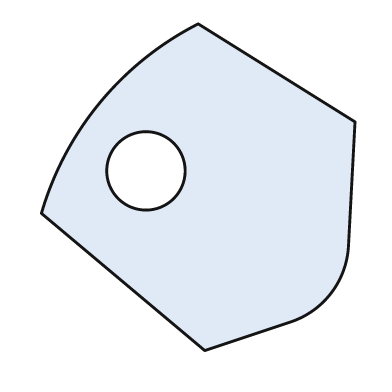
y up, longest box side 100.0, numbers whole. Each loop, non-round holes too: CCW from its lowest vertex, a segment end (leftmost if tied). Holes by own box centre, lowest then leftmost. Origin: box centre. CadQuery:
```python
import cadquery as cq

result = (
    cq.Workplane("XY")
    .moveTo(2.0, -50.0)
    .lineTo(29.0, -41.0)
    .threePointArc((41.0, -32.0), (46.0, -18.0))
    .lineTo(48.0, 20.0)
    .lineTo(0.0, 50.0)
    .threePointArc((-30.0, 26.0), (-48.0, -8.0))
    .close()
    .moveTo(-16.0, 5.0)
    .circle(12.0)
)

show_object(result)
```